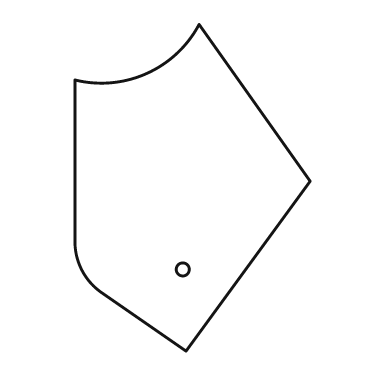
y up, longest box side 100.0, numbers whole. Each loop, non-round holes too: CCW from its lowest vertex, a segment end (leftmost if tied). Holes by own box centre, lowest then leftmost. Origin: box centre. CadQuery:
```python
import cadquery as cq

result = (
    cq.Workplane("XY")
    .moveTo(-2.0, -50.0)
    .lineTo(36.0, 2.0)
    .lineTo(2.0, 50.0)
    .threePointArc((-14.0, 35.0), (-36.0, 33.0))
    .lineTo(-36.0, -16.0)
    .threePointArc((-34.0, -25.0), (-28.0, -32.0))
    .close()
    .moveTo(-3.0, -25.0)
    .circle(2.0)
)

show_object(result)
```